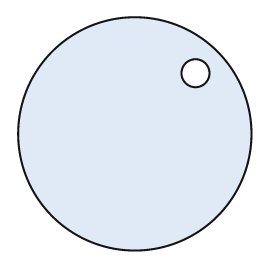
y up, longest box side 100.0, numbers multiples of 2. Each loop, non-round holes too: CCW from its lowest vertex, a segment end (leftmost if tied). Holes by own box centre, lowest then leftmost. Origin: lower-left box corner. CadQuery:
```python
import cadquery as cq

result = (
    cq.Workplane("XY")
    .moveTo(50.0, 50.0)
    .circle(50.0)
    .moveTo(76.0, 76.0)
    .circle(6.0)
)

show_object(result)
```